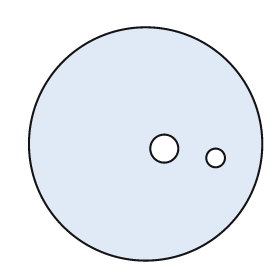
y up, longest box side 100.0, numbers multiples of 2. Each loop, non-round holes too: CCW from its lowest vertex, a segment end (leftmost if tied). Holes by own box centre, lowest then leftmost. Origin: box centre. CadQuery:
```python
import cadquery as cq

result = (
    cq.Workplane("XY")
    .moveTo(0.0, 0.0)
    .circle(50.0)
    .moveTo(30.0, -6.0)
    .circle(4.0)
    .moveTo(8.0, -2.0)
    .circle(6.0)
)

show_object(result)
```